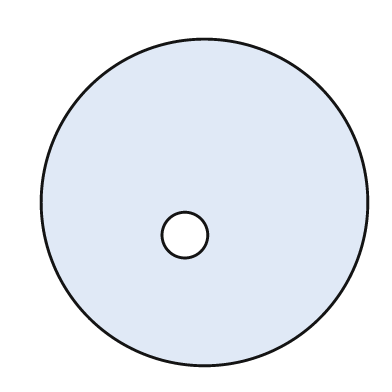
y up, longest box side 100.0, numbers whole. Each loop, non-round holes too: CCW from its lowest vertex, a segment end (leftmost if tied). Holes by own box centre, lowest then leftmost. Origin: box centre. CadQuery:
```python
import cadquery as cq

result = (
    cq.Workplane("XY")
    .moveTo(0.0, 0.0)
    .circle(50.0)
    .moveTo(-6.0, -10.0)
    .circle(7.0)
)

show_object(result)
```